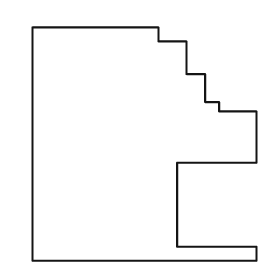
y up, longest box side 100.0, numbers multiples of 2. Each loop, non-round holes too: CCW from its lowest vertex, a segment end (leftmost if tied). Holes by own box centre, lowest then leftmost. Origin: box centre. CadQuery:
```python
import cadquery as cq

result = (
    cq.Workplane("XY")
    .moveTo(-48.0, -50.0)
    .lineTo(48.0, -50.0)
    .lineTo(48.0, -44.0)
    .lineTo(14.0, -44.0)
    .lineTo(14.0, -8.0)
    .lineTo(48.0, -8.0)
    .lineTo(48.0, 14.0)
    .lineTo(32.0, 14.0)
    .lineTo(32.0, 18.0)
    .lineTo(26.0, 18.0)
    .lineTo(26.0, 30.0)
    .lineTo(18.0, 30.0)
    .lineTo(18.0, 44.0)
    .lineTo(6.0, 44.0)
    .lineTo(6.0, 50.0)
    .lineTo(-48.0, 50.0)
    .close()
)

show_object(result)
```